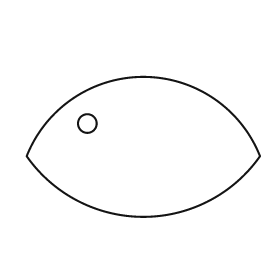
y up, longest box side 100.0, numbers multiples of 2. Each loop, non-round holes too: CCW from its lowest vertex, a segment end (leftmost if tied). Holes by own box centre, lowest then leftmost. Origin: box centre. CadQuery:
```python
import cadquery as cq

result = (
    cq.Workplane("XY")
    .moveTo(-50.0, -4.0)
    .threePointArc((0.0, -30.0), (50.0, -4.0))
    .threePointArc((0.0, 30.0), (-50.0, -4.0))
    .close()
    .moveTo(-24.0, 10.0)
    .circle(4.0)
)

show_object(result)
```